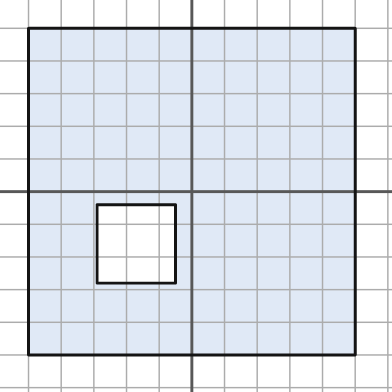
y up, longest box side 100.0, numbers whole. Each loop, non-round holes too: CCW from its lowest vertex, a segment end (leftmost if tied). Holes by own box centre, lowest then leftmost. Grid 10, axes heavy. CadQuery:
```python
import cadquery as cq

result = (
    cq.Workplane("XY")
    .moveTo(-50.0, -50.0)
    .lineTo(50.0, -50.0)
    .lineTo(50.0, 50.0)
    .lineTo(-50.0, 50.0)
    .close()
    .moveTo(-29.0, -28.0)
    .lineTo(-5.0, -28.0)
    .lineTo(-5.0, -4.0)
    .lineTo(-29.0, -4.0)
    .close()
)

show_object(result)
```